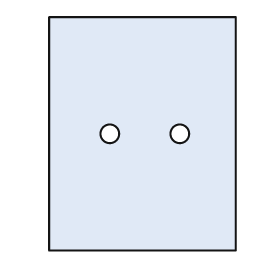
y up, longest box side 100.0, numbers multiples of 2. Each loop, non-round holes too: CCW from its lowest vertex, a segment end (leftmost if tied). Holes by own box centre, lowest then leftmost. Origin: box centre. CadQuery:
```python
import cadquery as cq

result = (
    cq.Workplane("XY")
    .moveTo(-40.0, -50.0)
    .lineTo(40.0, -50.0)
    .lineTo(40.0, 50.0)
    .lineTo(-40.0, 50.0)
    .close()
    .moveTo(-14.0, 0.0)
    .circle(4.0)
    .moveTo(16.0, 0.0)
    .circle(4.0)
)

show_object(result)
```